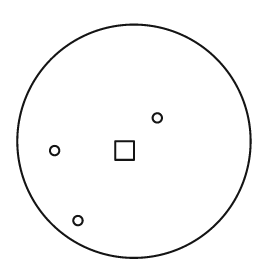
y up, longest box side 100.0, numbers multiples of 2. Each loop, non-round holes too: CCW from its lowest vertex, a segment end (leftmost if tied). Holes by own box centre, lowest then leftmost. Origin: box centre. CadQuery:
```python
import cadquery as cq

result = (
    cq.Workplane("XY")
    .moveTo(0.0, 0.0)
    .circle(50.0)
    .moveTo(-24.0, -34.0)
    .circle(2.0)
    .moveTo(-34.0, -4.0)
    .circle(2.0)
    .moveTo(-8.0, -8.0)
    .lineTo(0.0, -8.0)
    .lineTo(0.0, 0.0)
    .lineTo(-8.0, 0.0)
    .close()
    .moveTo(10.0, 10.0)
    .circle(2.0)
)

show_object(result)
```